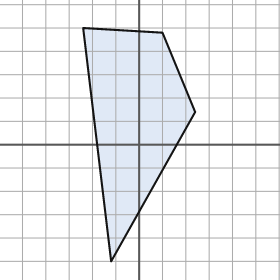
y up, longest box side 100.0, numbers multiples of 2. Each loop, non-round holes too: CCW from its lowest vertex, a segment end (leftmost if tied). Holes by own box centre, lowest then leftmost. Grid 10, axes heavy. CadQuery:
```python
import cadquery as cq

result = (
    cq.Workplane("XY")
    .moveTo(-12.0, -50.0)
    .lineTo(24.0, 14.0)
    .lineTo(10.0, 48.0)
    .lineTo(-24.0, 50.0)
    .close()
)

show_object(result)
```